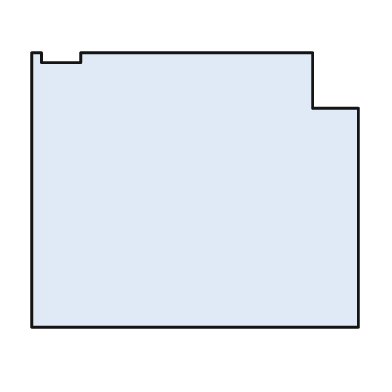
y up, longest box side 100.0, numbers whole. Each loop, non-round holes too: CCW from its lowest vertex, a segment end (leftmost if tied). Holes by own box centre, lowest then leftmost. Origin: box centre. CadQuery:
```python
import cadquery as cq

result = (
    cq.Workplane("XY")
    .moveTo(-50.0, -42.0)
    .lineTo(50.0, -42.0)
    .lineTo(50.0, 25.0)
    .lineTo(36.0, 25.0)
    .lineTo(36.0, 42.0)
    .lineTo(-35.0, 42.0)
    .lineTo(-35.0, 39.0)
    .lineTo(-47.0, 39.0)
    .lineTo(-47.0, 42.0)
    .lineTo(-50.0, 42.0)
    .close()
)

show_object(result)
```